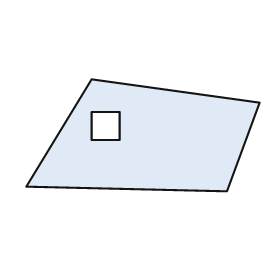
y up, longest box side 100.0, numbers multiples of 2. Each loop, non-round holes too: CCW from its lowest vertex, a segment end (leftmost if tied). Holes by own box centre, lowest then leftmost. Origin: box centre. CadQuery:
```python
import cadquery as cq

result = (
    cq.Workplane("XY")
    .moveTo(36.0, -24.0)
    .lineTo(50.0, 14.0)
    .lineTo(-22.0, 24.0)
    .lineTo(-50.0, -22.0)
    .close()
    .moveTo(-22.0, -2.0)
    .lineTo(-10.0, -2.0)
    .lineTo(-10.0, 10.0)
    .lineTo(-22.0, 10.0)
    .close()
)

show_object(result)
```